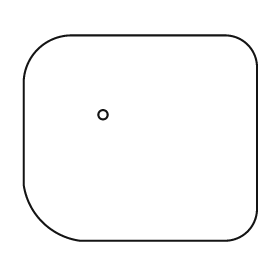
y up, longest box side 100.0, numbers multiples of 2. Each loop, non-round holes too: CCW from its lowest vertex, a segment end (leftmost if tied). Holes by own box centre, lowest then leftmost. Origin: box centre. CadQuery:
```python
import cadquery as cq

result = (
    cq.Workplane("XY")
    .moveTo(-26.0, -44.0)
    .lineTo(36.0, -44.0)
    .threePointArc((46.0, -40.0), (50.0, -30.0))
    .lineTo(50.0, 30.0)
    .threePointArc((46.0, 40.0), (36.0, 44.0))
    .lineTo(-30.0, 44.0)
    .threePointArc((-44.0, 38.0), (-50.0, 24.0))
    .lineTo(-50.0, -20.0)
    .threePointArc((-42.0, -36.0), (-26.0, -44.0))
    .close()
    .moveTo(-16.0, 10.0)
    .circle(2.0)
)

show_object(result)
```